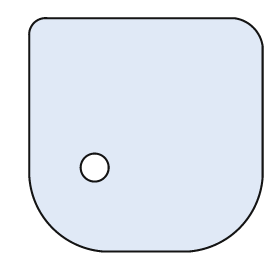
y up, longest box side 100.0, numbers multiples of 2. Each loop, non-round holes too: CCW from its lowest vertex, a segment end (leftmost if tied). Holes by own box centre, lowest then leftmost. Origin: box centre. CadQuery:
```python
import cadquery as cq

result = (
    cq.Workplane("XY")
    .moveTo(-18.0, -50.0)
    .lineTo(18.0, -50.0)
    .threePointArc((40.0, -40.0), (50.0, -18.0))
    .lineTo(50.0, 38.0)
    .threePointArc((46.0, 46.0), (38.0, 50.0))
    .lineTo(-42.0, 50.0)
    .threePointArc((-48.0, 48.0), (-50.0, 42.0))
    .lineTo(-50.0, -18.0)
    .threePointArc((-40.0, -40.0), (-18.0, -50.0))
    .close()
    .moveTo(-22.0, -14.0)
    .circle(6.0)
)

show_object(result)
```